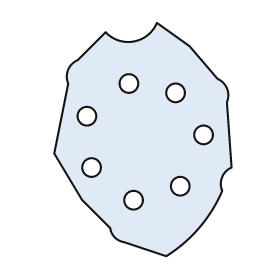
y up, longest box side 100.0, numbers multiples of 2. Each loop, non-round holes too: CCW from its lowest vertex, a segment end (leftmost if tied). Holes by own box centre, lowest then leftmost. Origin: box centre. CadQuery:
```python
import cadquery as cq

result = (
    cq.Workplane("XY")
    .moveTo(10.0, -50.0)
    .threePointArc((24.0, -38.0), (34.0, -22.0))
    .threePointArc((34.0, -16.0), (38.0, -12.0))
    .lineTo(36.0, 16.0)
    .threePointArc((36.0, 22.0), (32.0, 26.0))
    .lineTo(20.0, 40.0)
    .lineTo(6.0, 50.0)
    .threePointArc((-4.0, 42.0), (-16.0, 46.0))
    .lineTo(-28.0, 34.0)
    .threePointArc((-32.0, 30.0), (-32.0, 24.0))
    .lineTo(-38.0, -6.0)
    .lineTo(-26.0, -26.0)
    .lineTo(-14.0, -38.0)
    .threePointArc((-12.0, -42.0), (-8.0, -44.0))
    .close()
    .moveTo(-4.0, -26.0)
    .circle(4.0)
    .moveTo(16.0, -20.0)
    .circle(4.0)
    .moveTo(-22.0, -12.0)
    .circle(4.0)
    .moveTo(26.0, 2.0)
    .circle(4.0)
    .moveTo(-24.0, 10.0)
    .circle(4.0)
    .moveTo(14.0, 20.0)
    .circle(4.0)
    .moveTo(-6.0, 24.0)
    .circle(4.0)
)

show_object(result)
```